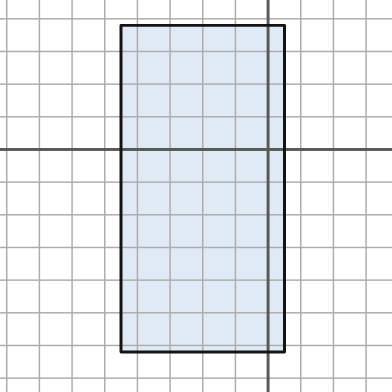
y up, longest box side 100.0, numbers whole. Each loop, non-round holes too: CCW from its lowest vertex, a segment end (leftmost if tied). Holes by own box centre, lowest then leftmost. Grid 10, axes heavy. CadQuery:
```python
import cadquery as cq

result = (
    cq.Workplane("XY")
    .moveTo(-45.0, -62.0)
    .lineTo(5.0, -62.0)
    .lineTo(5.0, 38.0)
    .lineTo(-45.0, 38.0)
    .close()
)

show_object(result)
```